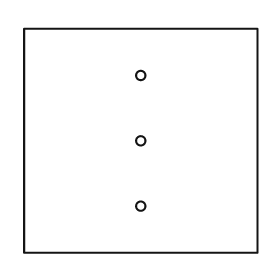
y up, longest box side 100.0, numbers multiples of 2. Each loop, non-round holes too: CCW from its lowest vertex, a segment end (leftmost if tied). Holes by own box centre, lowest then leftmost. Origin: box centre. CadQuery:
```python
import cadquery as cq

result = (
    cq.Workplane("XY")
    .moveTo(-50.0, -48.0)
    .lineTo(50.0, -48.0)
    .lineTo(50.0, 48.0)
    .lineTo(-50.0, 48.0)
    .close()
    .moveTo(0.0, -28.0)
    .circle(2.0)
    .moveTo(0.0, 0.0)
    .circle(2.0)
    .moveTo(0.0, 28.0)
    .circle(2.0)
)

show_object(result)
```